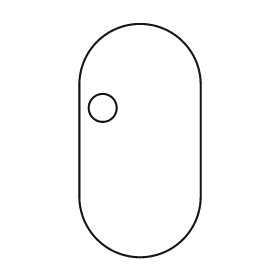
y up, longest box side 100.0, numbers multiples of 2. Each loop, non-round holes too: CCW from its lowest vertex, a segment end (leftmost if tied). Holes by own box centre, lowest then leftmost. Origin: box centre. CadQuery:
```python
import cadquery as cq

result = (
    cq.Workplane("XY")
    .moveTo(-26.0, -24.0)
    .threePointArc((0.0, -50.0), (26.0, -24.0))
    .lineTo(26.0, 24.0)
    .threePointArc((0.0, 50.0), (-26.0, 24.0))
    .close()
    .moveTo(-16.0, 14.0)
    .circle(6.0)
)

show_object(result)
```